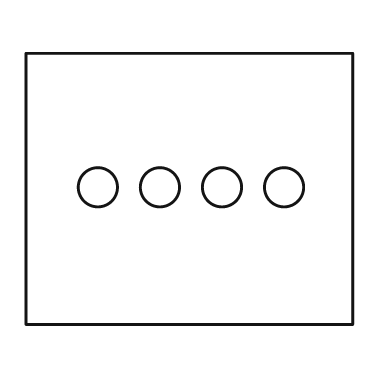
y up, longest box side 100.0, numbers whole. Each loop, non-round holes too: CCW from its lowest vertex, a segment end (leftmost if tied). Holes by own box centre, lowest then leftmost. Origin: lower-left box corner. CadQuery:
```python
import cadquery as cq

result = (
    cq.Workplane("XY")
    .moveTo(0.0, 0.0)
    .lineTo(100.0, 0.0)
    .lineTo(100.0, 83.0)
    .lineTo(0.0, 83.0)
    .close()
    .moveTo(22.0, 42.0)
    .circle(6.0)
    .moveTo(41.0, 42.0)
    .circle(6.0)
    .moveTo(60.0, 42.0)
    .circle(6.0)
    .moveTo(79.0, 42.0)
    .circle(6.0)
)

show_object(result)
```